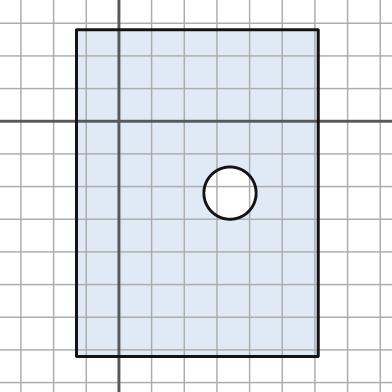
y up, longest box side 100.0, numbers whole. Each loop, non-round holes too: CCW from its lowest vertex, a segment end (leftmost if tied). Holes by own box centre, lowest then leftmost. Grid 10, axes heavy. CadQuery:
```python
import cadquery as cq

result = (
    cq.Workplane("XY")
    .moveTo(-13.0, -72.0)
    .lineTo(61.0, -72.0)
    .lineTo(61.0, 28.0)
    .lineTo(-13.0, 28.0)
    .close()
    .moveTo(34.0, -22.0)
    .circle(8.0)
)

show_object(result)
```